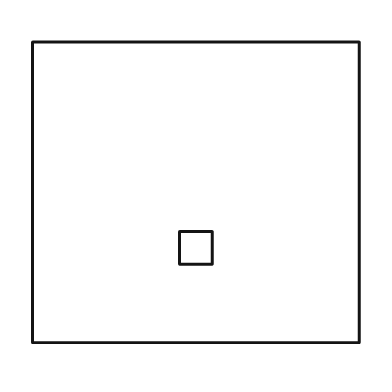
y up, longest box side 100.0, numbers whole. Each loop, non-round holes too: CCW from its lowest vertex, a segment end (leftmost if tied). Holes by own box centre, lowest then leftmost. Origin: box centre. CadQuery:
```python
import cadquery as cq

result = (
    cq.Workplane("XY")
    .moveTo(-50.0, -46.0)
    .lineTo(50.0, -46.0)
    .lineTo(50.0, 46.0)
    .lineTo(-50.0, 46.0)
    .close()
    .moveTo(-5.0, -22.0)
    .lineTo(5.0, -22.0)
    .lineTo(5.0, -12.0)
    .lineTo(-5.0, -12.0)
    .close()
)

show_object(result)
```